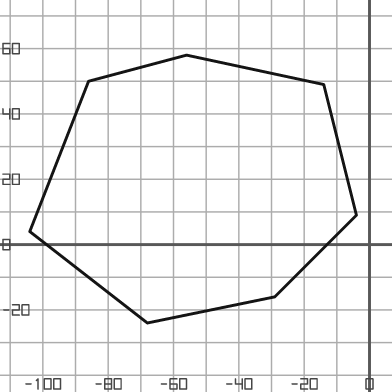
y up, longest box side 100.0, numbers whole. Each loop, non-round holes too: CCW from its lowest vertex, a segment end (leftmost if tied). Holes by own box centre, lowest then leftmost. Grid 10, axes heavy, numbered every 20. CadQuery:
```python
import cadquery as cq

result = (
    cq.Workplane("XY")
    .moveTo(-68.0, -24.0)
    .lineTo(-29.0, -16.0)
    .lineTo(-4.0, 9.0)
    .lineTo(-14.0, 49.0)
    .lineTo(-56.0, 58.0)
    .lineTo(-86.0, 50.0)
    .lineTo(-104.0, 4.0)
    .close()
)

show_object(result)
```